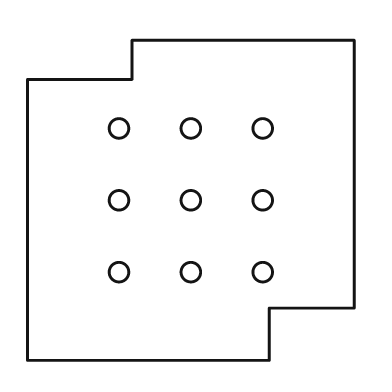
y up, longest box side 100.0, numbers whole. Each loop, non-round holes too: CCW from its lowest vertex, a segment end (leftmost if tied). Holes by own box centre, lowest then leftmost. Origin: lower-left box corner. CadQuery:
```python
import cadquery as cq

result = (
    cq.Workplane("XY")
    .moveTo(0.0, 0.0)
    .lineTo(74.0, 0.0)
    .lineTo(74.0, 16.0)
    .lineTo(100.0, 16.0)
    .lineTo(100.0, 98.0)
    .lineTo(32.0, 98.0)
    .lineTo(32.0, 86.0)
    .lineTo(0.0, 86.0)
    .close()
    .moveTo(28.0, 27.0)
    .circle(3.0)
    .moveTo(50.0, 27.0)
    .circle(3.0)
    .moveTo(72.0, 27.0)
    .circle(3.0)
    .moveTo(28.0, 49.0)
    .circle(3.0)
    .moveTo(50.0, 49.0)
    .circle(3.0)
    .moveTo(72.0, 49.0)
    .circle(3.0)
    .moveTo(28.0, 71.0)
    .circle(3.0)
    .moveTo(50.0, 71.0)
    .circle(3.0)
    .moveTo(72.0, 71.0)
    .circle(3.0)
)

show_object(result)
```